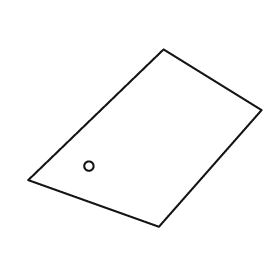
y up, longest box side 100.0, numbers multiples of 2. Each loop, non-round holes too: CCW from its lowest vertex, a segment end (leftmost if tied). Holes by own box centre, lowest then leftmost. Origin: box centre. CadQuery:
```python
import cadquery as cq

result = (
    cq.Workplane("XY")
    .moveTo(6.0, -38.0)
    .lineTo(50.0, 12.0)
    .lineTo(8.0, 38.0)
    .lineTo(-50.0, -18.0)
    .close()
    .moveTo(-24.0, -12.0)
    .circle(2.0)
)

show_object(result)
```